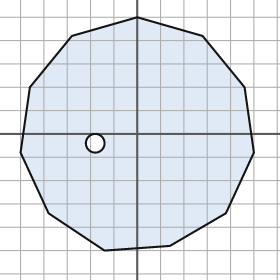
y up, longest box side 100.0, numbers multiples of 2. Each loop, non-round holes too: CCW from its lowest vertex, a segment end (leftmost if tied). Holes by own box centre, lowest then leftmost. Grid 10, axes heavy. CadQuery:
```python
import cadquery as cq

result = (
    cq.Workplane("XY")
    .moveTo(-14.0, -50.0)
    .lineTo(14.0, -48.0)
    .lineTo(38.0, -34.0)
    .lineTo(50.0, -8.0)
    .lineTo(46.0, 20.0)
    .lineTo(28.0, 42.0)
    .lineTo(0.0, 50.0)
    .lineTo(-28.0, 42.0)
    .lineTo(-46.0, 20.0)
    .lineTo(-50.0, -8.0)
    .lineTo(-38.0, -34.0)
    .close()
    .moveTo(-18.0, -4.0)
    .circle(4.0)
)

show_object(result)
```